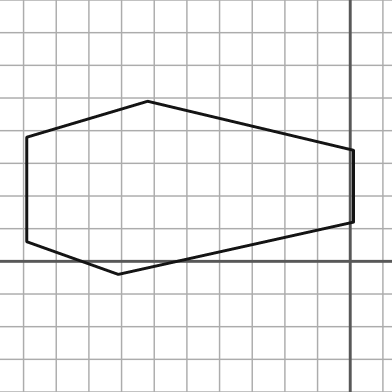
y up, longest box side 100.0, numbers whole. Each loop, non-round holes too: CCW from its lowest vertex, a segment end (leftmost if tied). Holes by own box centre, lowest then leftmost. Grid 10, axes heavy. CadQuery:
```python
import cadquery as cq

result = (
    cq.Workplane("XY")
    .moveTo(-71.0, -4.0)
    .lineTo(1.0, 12.0)
    .lineTo(1.0, 34.0)
    .lineTo(-62.0, 49.0)
    .lineTo(-99.0, 38.0)
    .lineTo(-99.0, 6.0)
    .close()
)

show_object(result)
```